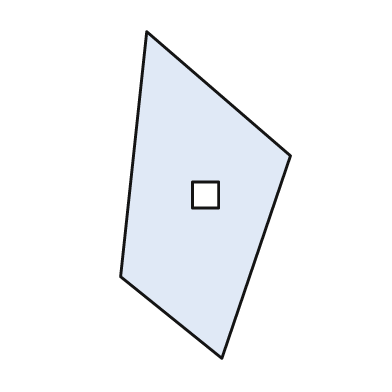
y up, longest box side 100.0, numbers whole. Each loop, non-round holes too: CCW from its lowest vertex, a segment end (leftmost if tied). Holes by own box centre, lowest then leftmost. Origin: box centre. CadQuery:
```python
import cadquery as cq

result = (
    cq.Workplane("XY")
    .moveTo(5.0, -50.0)
    .lineTo(26.0, 12.0)
    .lineTo(-18.0, 50.0)
    .lineTo(-26.0, -25.0)
    .close()
    .moveTo(-4.0, -4.0)
    .lineTo(4.0, -4.0)
    .lineTo(4.0, 4.0)
    .lineTo(-4.0, 4.0)
    .close()
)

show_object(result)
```